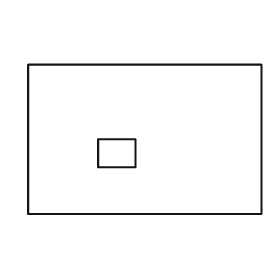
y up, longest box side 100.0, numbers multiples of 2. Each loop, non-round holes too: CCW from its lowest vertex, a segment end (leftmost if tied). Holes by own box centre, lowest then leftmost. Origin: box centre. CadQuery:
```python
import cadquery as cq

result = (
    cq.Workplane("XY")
    .moveTo(-50.0, -32.0)
    .lineTo(50.0, -32.0)
    .lineTo(50.0, 32.0)
    .lineTo(-50.0, 32.0)
    .close()
    .moveTo(-20.0, -12.0)
    .lineTo(-4.0, -12.0)
    .lineTo(-4.0, 0.0)
    .lineTo(-20.0, 0.0)
    .close()
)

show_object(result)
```